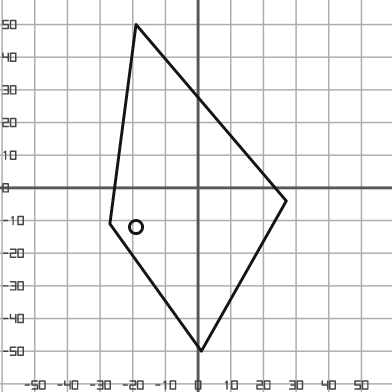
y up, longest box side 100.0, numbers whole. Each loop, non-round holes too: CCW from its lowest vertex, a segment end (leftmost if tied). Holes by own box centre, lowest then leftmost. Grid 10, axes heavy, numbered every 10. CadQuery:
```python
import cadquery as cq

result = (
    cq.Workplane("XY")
    .moveTo(1.0, -50.0)
    .lineTo(27.0, -4.0)
    .lineTo(-19.0, 50.0)
    .lineTo(-27.0, -11.0)
    .close()
    .moveTo(-19.0, -12.0)
    .circle(2.0)
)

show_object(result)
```